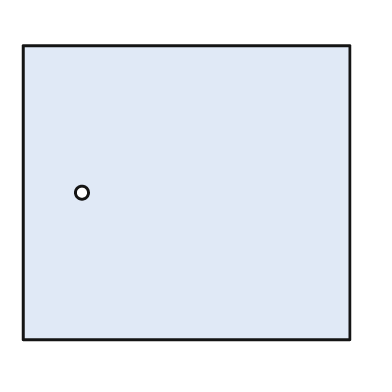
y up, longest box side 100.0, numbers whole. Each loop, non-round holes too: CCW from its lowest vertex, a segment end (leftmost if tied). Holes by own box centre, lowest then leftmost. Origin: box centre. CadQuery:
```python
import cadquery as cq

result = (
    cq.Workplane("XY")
    .moveTo(-50.0, -45.0)
    .lineTo(50.0, -45.0)
    .lineTo(50.0, 45.0)
    .lineTo(-50.0, 45.0)
    .close()
    .moveTo(-32.0, 0.0)
    .circle(2.0)
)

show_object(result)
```